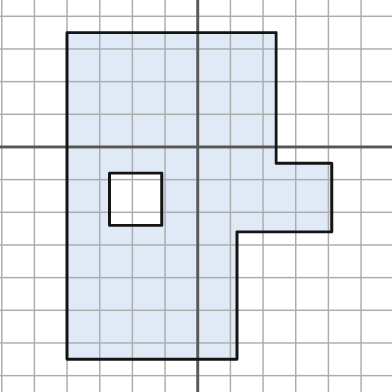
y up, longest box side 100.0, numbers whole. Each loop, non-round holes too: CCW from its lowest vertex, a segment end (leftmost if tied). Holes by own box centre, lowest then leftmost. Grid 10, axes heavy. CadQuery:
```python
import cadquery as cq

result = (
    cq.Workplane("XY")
    .moveTo(-40.0, -65.0)
    .lineTo(12.0, -65.0)
    .lineTo(12.0, -26.0)
    .lineTo(41.0, -26.0)
    .lineTo(41.0, -5.0)
    .lineTo(24.0, -5.0)
    .lineTo(24.0, 35.0)
    .lineTo(-40.0, 35.0)
    .close()
    .moveTo(-27.0, -24.0)
    .lineTo(-11.0, -24.0)
    .lineTo(-11.0, -8.0)
    .lineTo(-27.0, -8.0)
    .close()
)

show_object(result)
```